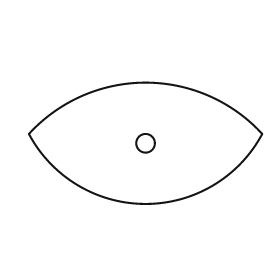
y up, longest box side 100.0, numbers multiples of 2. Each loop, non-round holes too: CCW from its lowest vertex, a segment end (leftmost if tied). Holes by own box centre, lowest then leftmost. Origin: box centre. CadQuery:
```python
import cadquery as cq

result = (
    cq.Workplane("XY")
    .moveTo(-50.0, 4.0)
    .threePointArc((0.0, -26.0), (50.0, 4.0))
    .threePointArc((0.0, 26.0), (-50.0, 4.0))
    .close()
    .moveTo(0.0, 0.0)
    .circle(4.0)
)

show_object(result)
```